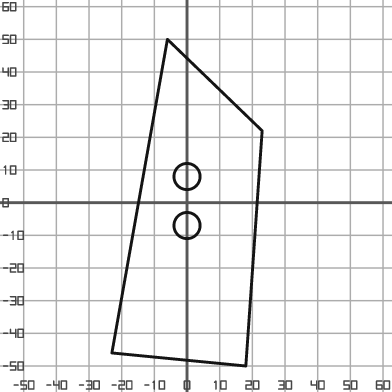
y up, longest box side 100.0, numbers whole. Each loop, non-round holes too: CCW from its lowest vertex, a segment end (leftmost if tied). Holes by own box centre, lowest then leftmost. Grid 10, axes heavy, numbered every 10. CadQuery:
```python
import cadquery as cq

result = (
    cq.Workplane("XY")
    .moveTo(18.0, -50.0)
    .lineTo(23.0, 22.0)
    .lineTo(-6.0, 50.0)
    .lineTo(-23.0, -46.0)
    .close()
    .moveTo(0.0, -7.0)
    .circle(4.0)
    .moveTo(0.0, 8.0)
    .circle(4.0)
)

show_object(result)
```